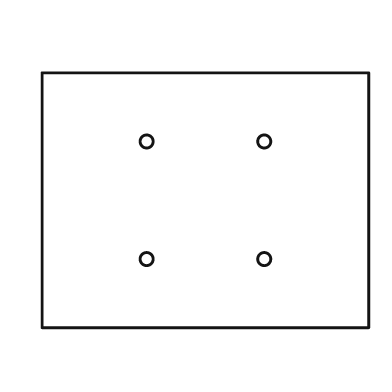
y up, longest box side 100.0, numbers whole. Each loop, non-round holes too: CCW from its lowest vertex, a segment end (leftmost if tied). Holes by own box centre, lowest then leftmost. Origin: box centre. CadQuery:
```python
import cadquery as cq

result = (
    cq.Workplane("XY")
    .moveTo(-50.0, -39.0)
    .lineTo(50.0, -39.0)
    .lineTo(50.0, 39.0)
    .lineTo(-50.0, 39.0)
    .close()
    .moveTo(-18.0, -18.0)
    .circle(2.0)
    .moveTo(18.0, -18.0)
    .circle(2.0)
    .moveTo(-18.0, 18.0)
    .circle(2.0)
    .moveTo(18.0, 18.0)
    .circle(2.0)
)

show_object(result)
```